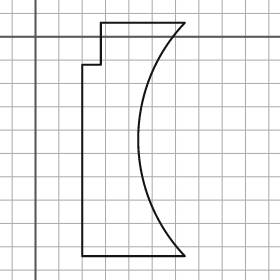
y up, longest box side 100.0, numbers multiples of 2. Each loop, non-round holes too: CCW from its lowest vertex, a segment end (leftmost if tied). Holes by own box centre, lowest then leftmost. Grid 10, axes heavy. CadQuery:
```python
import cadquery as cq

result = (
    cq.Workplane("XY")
    .moveTo(20.0, -94.0)
    .lineTo(64.0, -94.0)
    .threePointArc((44.0, -44.0), (64.0, 6.0))
    .lineTo(28.0, 6.0)
    .lineTo(28.0, -12.0)
    .lineTo(20.0, -12.0)
    .close()
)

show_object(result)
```